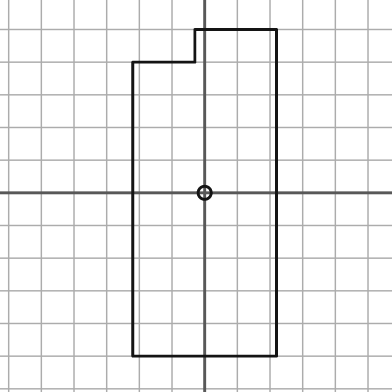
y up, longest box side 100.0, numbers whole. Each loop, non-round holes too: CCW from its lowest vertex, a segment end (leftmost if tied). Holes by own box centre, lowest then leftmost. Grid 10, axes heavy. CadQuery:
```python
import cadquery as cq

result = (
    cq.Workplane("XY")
    .moveTo(-22.0, -50.0)
    .lineTo(22.0, -50.0)
    .lineTo(22.0, 50.0)
    .lineTo(-3.0, 50.0)
    .lineTo(-3.0, 40.0)
    .lineTo(-22.0, 40.0)
    .close()
    .moveTo(0.0, 0.0)
    .circle(2.0)
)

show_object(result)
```